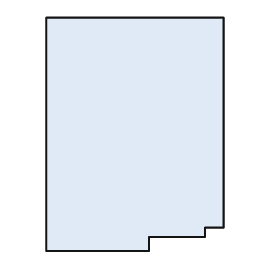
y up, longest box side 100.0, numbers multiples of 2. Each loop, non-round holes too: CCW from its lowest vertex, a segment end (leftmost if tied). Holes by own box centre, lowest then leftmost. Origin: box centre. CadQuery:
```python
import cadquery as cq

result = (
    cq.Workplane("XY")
    .moveTo(-38.0, -50.0)
    .lineTo(6.0, -50.0)
    .lineTo(6.0, -44.0)
    .lineTo(30.0, -44.0)
    .lineTo(30.0, -40.0)
    .lineTo(38.0, -40.0)
    .lineTo(38.0, 50.0)
    .lineTo(-38.0, 50.0)
    .close()
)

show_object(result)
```